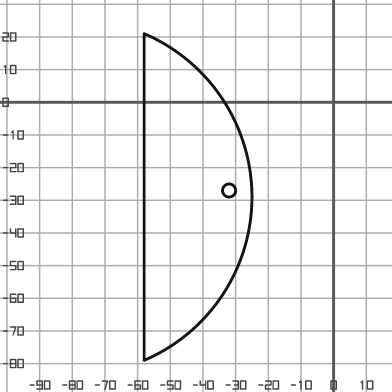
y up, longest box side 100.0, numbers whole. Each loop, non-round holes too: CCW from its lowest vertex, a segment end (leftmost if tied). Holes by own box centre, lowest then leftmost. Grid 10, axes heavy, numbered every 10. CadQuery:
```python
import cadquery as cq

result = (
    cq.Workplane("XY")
    .moveTo(-58.0, -79.0)
    .threePointArc((-25.0, -29.0), (-58.0, 21.0))
    .close()
    .moveTo(-32.0, -27.0)
    .circle(2.0)
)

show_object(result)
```